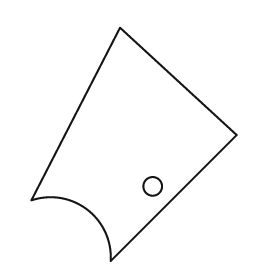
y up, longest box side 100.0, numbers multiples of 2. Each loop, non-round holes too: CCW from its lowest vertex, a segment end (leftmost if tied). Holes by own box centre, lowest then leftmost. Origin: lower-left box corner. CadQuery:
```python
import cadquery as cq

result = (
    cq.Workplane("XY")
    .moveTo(34.0, 0.0)
    .lineTo(88.0, 54.0)
    .lineTo(38.0, 100.0)
    .lineTo(0.0, 26.0)
    .threePointArc((24.0, 22.0), (34.0, 0.0))
    .close()
    .moveTo(52.0, 32.0)
    .circle(4.0)
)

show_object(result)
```